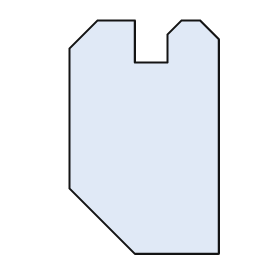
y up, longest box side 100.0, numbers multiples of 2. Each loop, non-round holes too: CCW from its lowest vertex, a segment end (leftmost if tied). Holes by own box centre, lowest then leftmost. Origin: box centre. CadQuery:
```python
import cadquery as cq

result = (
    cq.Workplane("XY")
    .moveTo(-4.0, -50.0)
    .lineTo(32.0, -50.0)
    .lineTo(32.0, 42.0)
    .lineTo(24.0, 50.0)
    .lineTo(16.0, 50.0)
    .lineTo(10.0, 44.0)
    .lineTo(10.0, 32.0)
    .lineTo(-4.0, 32.0)
    .lineTo(-4.0, 50.0)
    .lineTo(-20.0, 50.0)
    .lineTo(-32.0, 38.0)
    .lineTo(-32.0, -22.0)
    .close()
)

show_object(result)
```